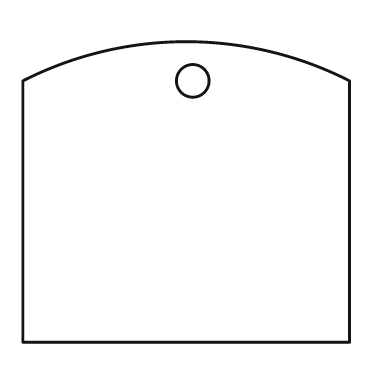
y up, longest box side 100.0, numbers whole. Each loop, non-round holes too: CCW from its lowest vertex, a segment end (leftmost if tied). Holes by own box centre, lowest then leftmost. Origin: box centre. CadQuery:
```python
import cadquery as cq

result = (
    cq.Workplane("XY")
    .moveTo(-50.0, -46.0)
    .lineTo(50.0, -46.0)
    .lineTo(50.0, 34.0)
    .threePointArc((0.0, 46.0), (-50.0, 34.0))
    .close()
    .moveTo(2.0, 34.0)
    .circle(5.0)
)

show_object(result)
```